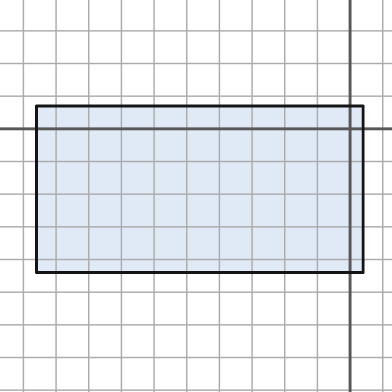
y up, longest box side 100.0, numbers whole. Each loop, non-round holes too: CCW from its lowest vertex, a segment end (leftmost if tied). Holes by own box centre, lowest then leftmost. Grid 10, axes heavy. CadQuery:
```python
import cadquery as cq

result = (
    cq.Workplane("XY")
    .moveTo(-96.0, -44.0)
    .lineTo(4.0, -44.0)
    .lineTo(4.0, 7.0)
    .lineTo(-96.0, 7.0)
    .close()
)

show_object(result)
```